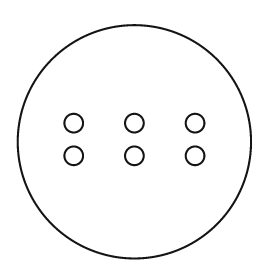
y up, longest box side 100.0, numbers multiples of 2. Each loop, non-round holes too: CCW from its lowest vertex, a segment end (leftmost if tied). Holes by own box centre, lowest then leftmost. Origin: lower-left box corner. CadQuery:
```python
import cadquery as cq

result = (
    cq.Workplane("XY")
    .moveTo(50.0, 50.0)
    .circle(50.0)
    .moveTo(24.0, 44.0)
    .circle(4.0)
    .moveTo(50.0, 44.0)
    .circle(4.0)
    .moveTo(76.0, 44.0)
    .circle(4.0)
    .moveTo(24.0, 58.0)
    .circle(4.0)
    .moveTo(50.0, 58.0)
    .circle(4.0)
    .moveTo(76.0, 58.0)
    .circle(4.0)
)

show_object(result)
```